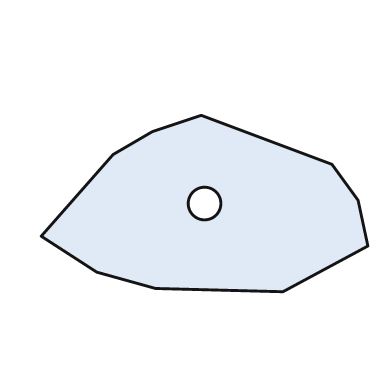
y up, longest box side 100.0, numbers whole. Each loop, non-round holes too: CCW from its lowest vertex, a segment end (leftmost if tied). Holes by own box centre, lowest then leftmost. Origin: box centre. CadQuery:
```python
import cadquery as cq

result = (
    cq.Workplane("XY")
    .moveTo(24.0, -27.0)
    .lineTo(50.0, -13.0)
    .lineTo(47.0, 1.0)
    .lineTo(39.0, 12.0)
    .lineTo(-1.0, 27.0)
    .lineTo(-16.0, 22.0)
    .lineTo(-28.0, 15.0)
    .lineTo(-50.0, -10.0)
    .lineTo(-33.0, -21.0)
    .lineTo(-15.0, -26.0)
    .close()
    .moveTo(0.0, 0.0)
    .circle(5.0)
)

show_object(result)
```